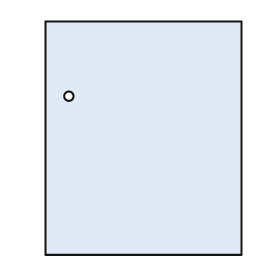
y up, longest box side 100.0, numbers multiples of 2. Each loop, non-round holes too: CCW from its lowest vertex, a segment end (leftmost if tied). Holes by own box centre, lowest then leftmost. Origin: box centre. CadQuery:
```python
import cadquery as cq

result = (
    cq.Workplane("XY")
    .moveTo(-42.0, -50.0)
    .lineTo(42.0, -50.0)
    .lineTo(42.0, 50.0)
    .lineTo(-42.0, 50.0)
    .close()
    .moveTo(-32.0, 18.0)
    .circle(2.0)
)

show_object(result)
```